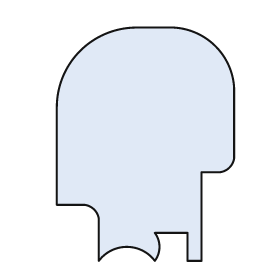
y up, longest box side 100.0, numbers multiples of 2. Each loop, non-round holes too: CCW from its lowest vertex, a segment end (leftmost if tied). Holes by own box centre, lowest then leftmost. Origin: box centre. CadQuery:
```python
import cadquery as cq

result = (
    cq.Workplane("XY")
    .moveTo(-20.0, -50.0)
    .threePointArc((-8.0, -44.0), (4.0, -50.0))
    .threePointArc((6.0, -44.0), (4.0, -38.0))
    .lineTo(18.0, -38.0)
    .lineTo(18.0, -50.0)
    .lineTo(24.0, -50.0)
    .lineTo(24.0, -12.0)
    .lineTo(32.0, -12.0)
    .threePointArc((36.0, -10.0), (38.0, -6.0))
    .lineTo(38.0, 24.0)
    .threePointArc((30.0, 42.0), (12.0, 50.0))
    .lineTo(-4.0, 50.0)
    .threePointArc((-28.0, 40.0), (-38.0, 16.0))
    .lineTo(-38.0, -26.0)
    .lineTo(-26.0, -26.0)
    .threePointArc((-22.0, -28.0), (-20.0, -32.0))
    .close()
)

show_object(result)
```